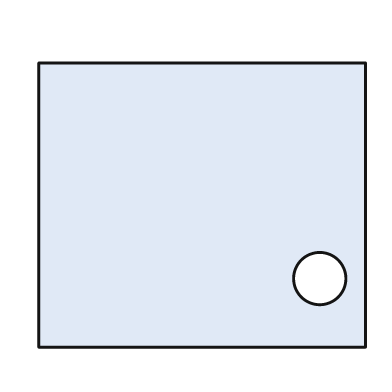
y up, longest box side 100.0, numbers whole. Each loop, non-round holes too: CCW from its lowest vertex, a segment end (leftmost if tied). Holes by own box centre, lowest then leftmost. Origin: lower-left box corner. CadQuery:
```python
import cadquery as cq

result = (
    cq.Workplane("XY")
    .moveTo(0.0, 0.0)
    .lineTo(100.0, 0.0)
    .lineTo(100.0, 87.0)
    .lineTo(0.0, 87.0)
    .close()
    .moveTo(86.0, 21.0)
    .circle(8.0)
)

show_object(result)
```